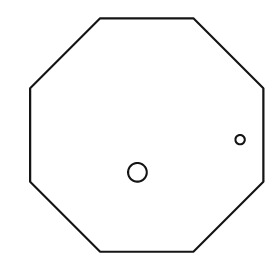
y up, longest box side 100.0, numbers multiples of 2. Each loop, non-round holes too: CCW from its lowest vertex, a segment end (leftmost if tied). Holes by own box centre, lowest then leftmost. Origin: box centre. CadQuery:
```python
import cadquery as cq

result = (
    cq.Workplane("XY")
    .moveTo(-20.0, -50.0)
    .lineTo(20.0, -50.0)
    .lineTo(50.0, -20.0)
    .lineTo(50.0, 20.0)
    .lineTo(20.0, 50.0)
    .lineTo(-20.0, 50.0)
    .lineTo(-50.0, 20.0)
    .lineTo(-50.0, -20.0)
    .close()
    .moveTo(-4.0, -16.0)
    .circle(4.0)
    .moveTo(40.0, -2.0)
    .circle(2.0)
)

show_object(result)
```